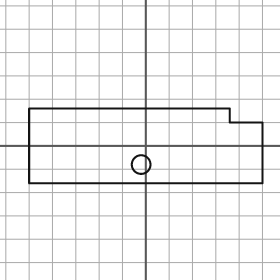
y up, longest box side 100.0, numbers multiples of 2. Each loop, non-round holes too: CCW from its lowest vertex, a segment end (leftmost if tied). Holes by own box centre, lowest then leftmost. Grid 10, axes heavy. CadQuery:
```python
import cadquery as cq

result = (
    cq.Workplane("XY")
    .moveTo(-50.0, -16.0)
    .lineTo(50.0, -16.0)
    .lineTo(50.0, 10.0)
    .lineTo(36.0, 10.0)
    .lineTo(36.0, 16.0)
    .lineTo(-50.0, 16.0)
    .close()
    .moveTo(-2.0, -8.0)
    .circle(4.0)
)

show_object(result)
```